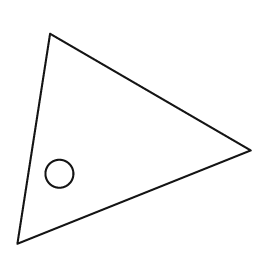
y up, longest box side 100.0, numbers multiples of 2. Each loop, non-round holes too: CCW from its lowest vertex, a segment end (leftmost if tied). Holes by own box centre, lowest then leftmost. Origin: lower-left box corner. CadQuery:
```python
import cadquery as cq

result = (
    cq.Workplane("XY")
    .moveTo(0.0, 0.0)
    .lineTo(100.0, 40.0)
    .lineTo(14.0, 90.0)
    .close()
    .moveTo(18.0, 30.0)
    .circle(6.0)
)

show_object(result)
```